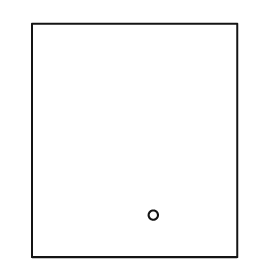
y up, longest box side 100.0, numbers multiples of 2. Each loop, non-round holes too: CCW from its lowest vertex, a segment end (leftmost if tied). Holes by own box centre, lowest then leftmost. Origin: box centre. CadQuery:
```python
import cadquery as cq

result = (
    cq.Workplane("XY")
    .moveTo(-44.0, -50.0)
    .lineTo(44.0, -50.0)
    .lineTo(44.0, 50.0)
    .lineTo(-44.0, 50.0)
    .close()
    .moveTo(8.0, -32.0)
    .circle(2.0)
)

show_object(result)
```